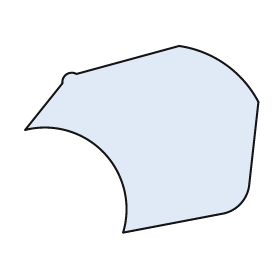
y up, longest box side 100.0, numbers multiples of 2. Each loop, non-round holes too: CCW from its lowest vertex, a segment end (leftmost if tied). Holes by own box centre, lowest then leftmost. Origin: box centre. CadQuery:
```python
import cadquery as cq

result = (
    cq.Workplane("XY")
    .moveTo(-8.0, -40.0)
    .lineTo(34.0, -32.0)
    .threePointArc((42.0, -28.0), (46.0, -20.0))
    .lineTo(50.0, 16.0)
    .threePointArc((36.0, 32.0), (16.0, 40.0))
    .lineTo(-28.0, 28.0)
    .threePointArc((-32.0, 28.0), (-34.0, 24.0))
    .lineTo(-50.0, 4.0)
    .threePointArc((-16.0, -6.0), (-8.0, -40.0))
    .close()
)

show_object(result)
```